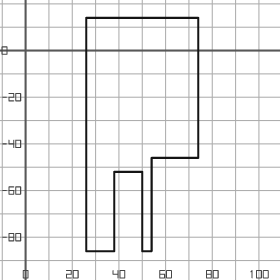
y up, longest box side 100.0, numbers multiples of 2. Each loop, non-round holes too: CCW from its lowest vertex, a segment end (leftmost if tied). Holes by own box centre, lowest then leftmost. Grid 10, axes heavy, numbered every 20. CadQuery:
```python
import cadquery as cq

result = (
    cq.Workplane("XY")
    .moveTo(26.0, -86.0)
    .lineTo(38.0, -86.0)
    .lineTo(38.0, -52.0)
    .lineTo(50.0, -52.0)
    .lineTo(50.0, -86.0)
    .lineTo(54.0, -86.0)
    .lineTo(54.0, -46.0)
    .lineTo(74.0, -46.0)
    .lineTo(74.0, 14.0)
    .lineTo(26.0, 14.0)
    .close()
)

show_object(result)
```